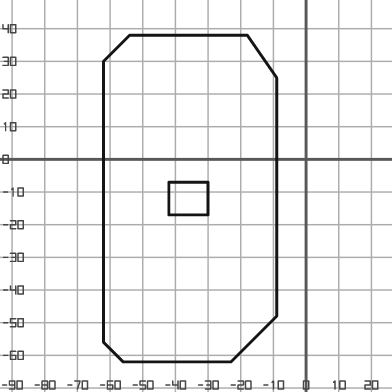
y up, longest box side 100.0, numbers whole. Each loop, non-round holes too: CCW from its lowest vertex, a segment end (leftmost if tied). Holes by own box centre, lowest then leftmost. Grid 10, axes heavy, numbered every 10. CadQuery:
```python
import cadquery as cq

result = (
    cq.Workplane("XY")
    .moveTo(-56.0, -62.0)
    .lineTo(-23.0, -62.0)
    .lineTo(-9.0, -48.0)
    .lineTo(-9.0, 25.0)
    .lineTo(-18.0, 38.0)
    .lineTo(-54.0, 38.0)
    .lineTo(-62.0, 30.0)
    .lineTo(-62.0, -56.0)
    .close()
    .moveTo(-42.0, -17.0)
    .lineTo(-30.0, -17.0)
    .lineTo(-30.0, -7.0)
    .lineTo(-42.0, -7.0)
    .close()
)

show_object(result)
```